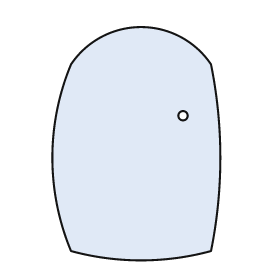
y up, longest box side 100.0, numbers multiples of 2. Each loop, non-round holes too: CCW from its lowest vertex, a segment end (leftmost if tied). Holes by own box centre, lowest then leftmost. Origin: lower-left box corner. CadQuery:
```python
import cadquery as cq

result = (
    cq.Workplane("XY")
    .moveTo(8.0, 4.0)
    .threePointArc((38.0, 0.0), (68.0, 4.0))
    .threePointArc((72.0, 44.0), (68.0, 84.0))
    .threePointArc((38.0, 100.0), (8.0, 84.0))
    .threePointArc((0.0, 44.0), (8.0, 4.0))
    .close()
    .moveTo(56.0, 62.0)
    .circle(2.0)
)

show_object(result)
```